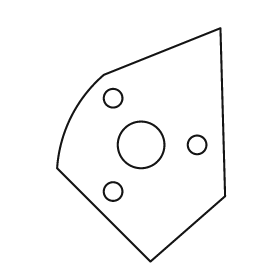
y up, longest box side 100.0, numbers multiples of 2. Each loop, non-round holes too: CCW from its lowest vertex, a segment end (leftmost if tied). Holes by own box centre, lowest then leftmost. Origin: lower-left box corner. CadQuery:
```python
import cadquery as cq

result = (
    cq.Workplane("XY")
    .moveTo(40.0, 0.0)
    .lineTo(72.0, 28.0)
    .lineTo(70.0, 100.0)
    .lineTo(20.0, 80.0)
    .threePointArc((6.0, 62.0), (0.0, 40.0))
    .close()
    .moveTo(24.0, 30.0)
    .circle(4.0)
    .moveTo(36.0, 50.0)
    .circle(10.0)
    .moveTo(60.0, 50.0)
    .circle(4.0)
    .moveTo(24.0, 70.0)
    .circle(4.0)
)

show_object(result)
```